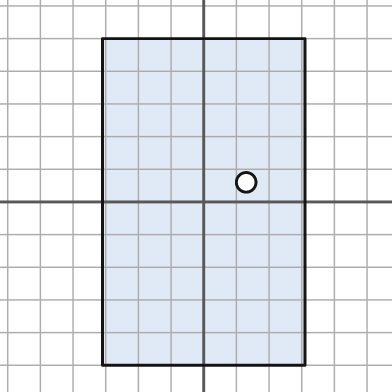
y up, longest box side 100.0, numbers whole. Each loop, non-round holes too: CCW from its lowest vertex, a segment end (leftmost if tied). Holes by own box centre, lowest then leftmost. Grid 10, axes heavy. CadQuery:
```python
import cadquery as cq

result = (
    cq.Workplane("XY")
    .moveTo(-31.0, -50.0)
    .lineTo(31.0, -50.0)
    .lineTo(31.0, 50.0)
    .lineTo(-31.0, 50.0)
    .close()
    .moveTo(13.0, 6.0)
    .circle(3.0)
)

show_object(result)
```